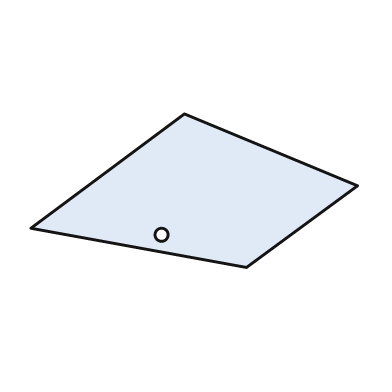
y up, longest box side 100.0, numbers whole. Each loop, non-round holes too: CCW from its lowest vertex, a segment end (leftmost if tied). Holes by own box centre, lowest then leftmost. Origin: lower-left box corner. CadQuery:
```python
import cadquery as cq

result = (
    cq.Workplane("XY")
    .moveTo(66.0, 0.0)
    .lineTo(100.0, 25.0)
    .lineTo(47.0, 47.0)
    .lineTo(0.0, 12.0)
    .close()
    .moveTo(40.0, 10.0)
    .circle(2.0)
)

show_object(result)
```